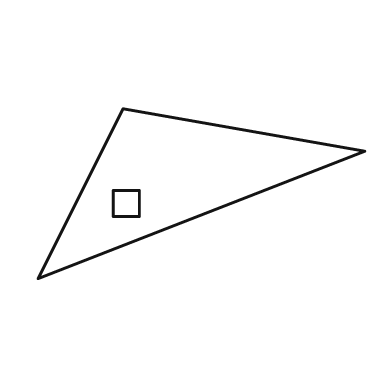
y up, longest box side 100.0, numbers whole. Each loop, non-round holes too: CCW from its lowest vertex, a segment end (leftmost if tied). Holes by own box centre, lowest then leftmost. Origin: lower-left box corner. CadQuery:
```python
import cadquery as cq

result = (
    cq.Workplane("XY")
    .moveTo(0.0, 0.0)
    .lineTo(100.0, 39.0)
    .lineTo(26.0, 52.0)
    .close()
    .moveTo(23.0, 19.0)
    .lineTo(31.0, 19.0)
    .lineTo(31.0, 27.0)
    .lineTo(23.0, 27.0)
    .close()
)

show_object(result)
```